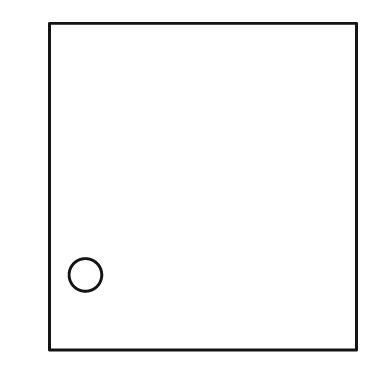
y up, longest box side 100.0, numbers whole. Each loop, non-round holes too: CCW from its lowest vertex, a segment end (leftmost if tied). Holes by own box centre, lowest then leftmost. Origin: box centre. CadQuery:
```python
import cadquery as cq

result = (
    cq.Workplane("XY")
    .moveTo(-47.0, -50.0)
    .lineTo(47.0, -50.0)
    .lineTo(47.0, 50.0)
    .lineTo(-47.0, 50.0)
    .close()
    .moveTo(-36.0, -27.0)
    .circle(5.0)
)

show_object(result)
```